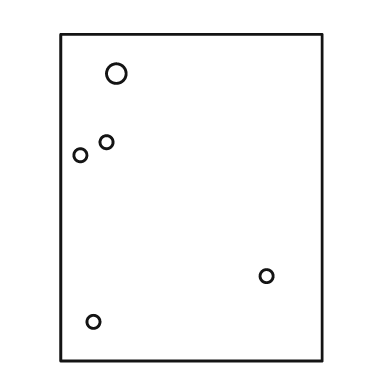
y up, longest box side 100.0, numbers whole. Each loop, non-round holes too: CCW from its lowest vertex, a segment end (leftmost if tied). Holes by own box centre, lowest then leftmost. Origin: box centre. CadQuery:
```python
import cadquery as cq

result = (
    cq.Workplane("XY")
    .moveTo(-40.0, -50.0)
    .lineTo(40.0, -50.0)
    .lineTo(40.0, 50.0)
    .lineTo(-40.0, 50.0)
    .close()
    .moveTo(-30.0, -38.0)
    .circle(2.0)
    .moveTo(23.0, -24.0)
    .circle(2.0)
    .moveTo(-34.0, 13.0)
    .circle(2.0)
    .moveTo(-26.0, 17.0)
    .circle(2.0)
    .moveTo(-23.0, 38.0)
    .circle(3.0)
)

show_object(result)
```